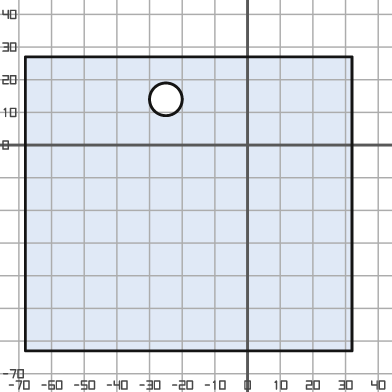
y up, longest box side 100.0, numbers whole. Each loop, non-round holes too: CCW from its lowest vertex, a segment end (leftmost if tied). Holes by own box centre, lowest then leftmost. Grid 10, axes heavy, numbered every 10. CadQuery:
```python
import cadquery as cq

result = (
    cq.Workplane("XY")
    .moveTo(-68.0, -63.0)
    .lineTo(32.0, -63.0)
    .lineTo(32.0, 27.0)
    .lineTo(-68.0, 27.0)
    .close()
    .moveTo(-25.0, 14.0)
    .circle(5.0)
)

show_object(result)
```